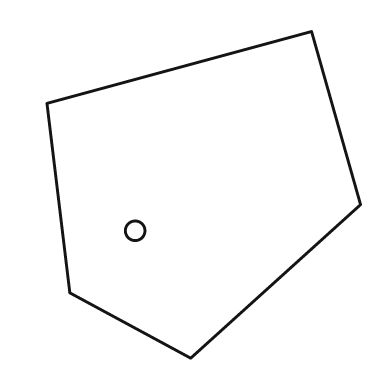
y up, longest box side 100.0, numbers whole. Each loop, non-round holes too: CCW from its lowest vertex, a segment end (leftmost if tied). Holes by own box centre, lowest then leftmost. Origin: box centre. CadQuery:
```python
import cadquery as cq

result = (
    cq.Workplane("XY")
    .moveTo(-4.0, -50.0)
    .lineTo(48.0, -3.0)
    .lineTo(33.0, 50.0)
    .lineTo(-48.0, 28.0)
    .lineTo(-41.0, -30.0)
    .close()
    .moveTo(-21.0, -11.0)
    .circle(3.0)
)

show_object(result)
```